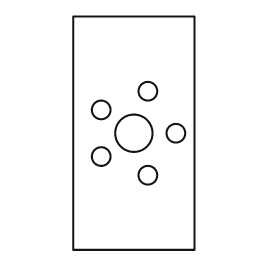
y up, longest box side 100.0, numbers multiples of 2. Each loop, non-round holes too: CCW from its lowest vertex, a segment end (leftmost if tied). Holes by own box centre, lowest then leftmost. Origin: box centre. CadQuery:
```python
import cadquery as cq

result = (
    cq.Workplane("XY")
    .moveTo(-26.0, -50.0)
    .lineTo(26.0, -50.0)
    .lineTo(26.0, 50.0)
    .lineTo(-26.0, 50.0)
    .close()
    .moveTo(6.0, -18.0)
    .circle(4.0)
    .moveTo(-14.0, -10.0)
    .circle(4.0)
    .moveTo(0.0, 0.0)
    .circle(8.0)
    .moveTo(18.0, 0.0)
    .circle(4.0)
    .moveTo(-14.0, 10.0)
    .circle(4.0)
    .moveTo(6.0, 18.0)
    .circle(4.0)
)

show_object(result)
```